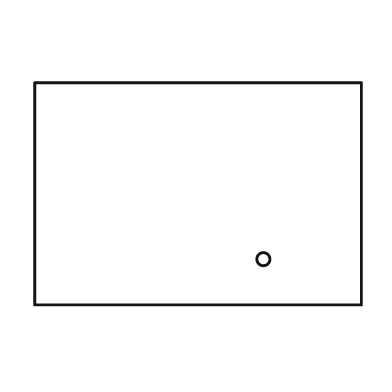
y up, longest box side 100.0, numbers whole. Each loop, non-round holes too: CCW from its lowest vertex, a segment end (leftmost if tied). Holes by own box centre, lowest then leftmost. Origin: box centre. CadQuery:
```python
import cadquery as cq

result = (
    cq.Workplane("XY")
    .moveTo(-50.0, -34.0)
    .lineTo(50.0, -34.0)
    .lineTo(50.0, 34.0)
    .lineTo(-50.0, 34.0)
    .close()
    .moveTo(20.0, -20.0)
    .circle(2.0)
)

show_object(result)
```